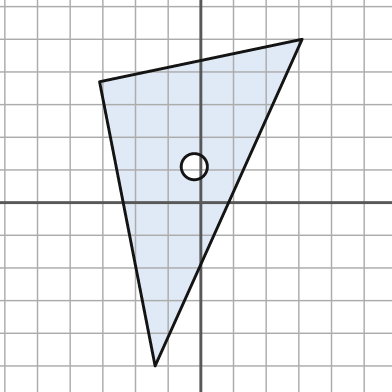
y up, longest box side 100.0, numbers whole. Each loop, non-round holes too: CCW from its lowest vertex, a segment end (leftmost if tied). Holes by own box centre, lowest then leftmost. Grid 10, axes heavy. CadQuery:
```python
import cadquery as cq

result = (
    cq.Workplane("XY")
    .moveTo(-14.0, -50.0)
    .lineTo(31.0, 50.0)
    .lineTo(-31.0, 37.0)
    .close()
    .moveTo(-2.0, 11.0)
    .circle(4.0)
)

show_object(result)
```